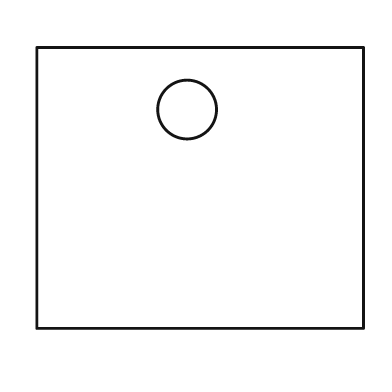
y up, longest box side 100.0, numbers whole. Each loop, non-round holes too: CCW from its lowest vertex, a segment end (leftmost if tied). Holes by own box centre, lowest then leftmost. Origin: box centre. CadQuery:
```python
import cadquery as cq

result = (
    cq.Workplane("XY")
    .moveTo(-50.0, -43.0)
    .lineTo(50.0, -43.0)
    .lineTo(50.0, 43.0)
    .lineTo(-50.0, 43.0)
    .close()
    .moveTo(-4.0, 24.0)
    .circle(9.0)
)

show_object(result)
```